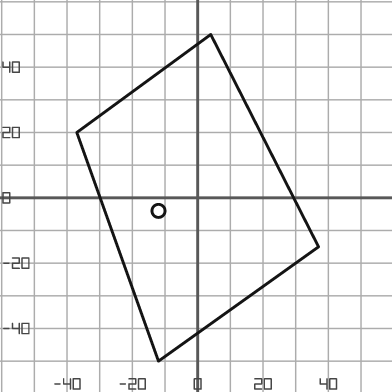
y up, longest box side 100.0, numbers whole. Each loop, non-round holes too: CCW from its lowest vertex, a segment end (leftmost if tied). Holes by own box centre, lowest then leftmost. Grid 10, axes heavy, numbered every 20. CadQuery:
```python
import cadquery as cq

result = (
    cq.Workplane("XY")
    .moveTo(-12.0, -50.0)
    .lineTo(37.0, -15.0)
    .lineTo(4.0, 50.0)
    .lineTo(-37.0, 20.0)
    .close()
    .moveTo(-12.0, -4.0)
    .circle(2.0)
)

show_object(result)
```